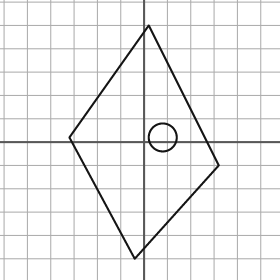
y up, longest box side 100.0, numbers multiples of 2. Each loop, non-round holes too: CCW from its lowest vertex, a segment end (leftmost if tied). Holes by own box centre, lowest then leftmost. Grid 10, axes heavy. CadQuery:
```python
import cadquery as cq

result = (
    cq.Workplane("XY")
    .moveTo(-4.0, -50.0)
    .lineTo(32.0, -10.0)
    .lineTo(2.0, 50.0)
    .lineTo(-32.0, 2.0)
    .close()
    .moveTo(8.0, 2.0)
    .circle(6.0)
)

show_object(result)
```